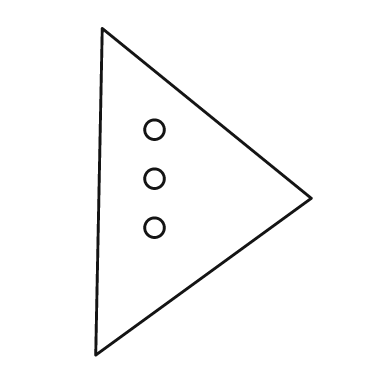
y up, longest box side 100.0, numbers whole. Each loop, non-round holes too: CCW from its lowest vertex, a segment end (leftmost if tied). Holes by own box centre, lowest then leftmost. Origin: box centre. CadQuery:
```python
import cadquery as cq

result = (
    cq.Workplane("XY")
    .moveTo(-33.0, -50.0)
    .lineTo(33.0, -2.0)
    .lineTo(-31.0, 50.0)
    .close()
    .moveTo(-15.0, -11.0)
    .circle(3.0)
    .moveTo(-15.0, 4.0)
    .circle(3.0)
    .moveTo(-15.0, 19.0)
    .circle(3.0)
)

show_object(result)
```